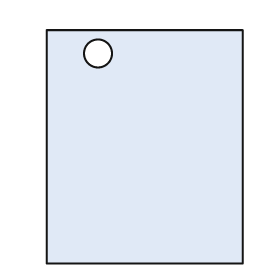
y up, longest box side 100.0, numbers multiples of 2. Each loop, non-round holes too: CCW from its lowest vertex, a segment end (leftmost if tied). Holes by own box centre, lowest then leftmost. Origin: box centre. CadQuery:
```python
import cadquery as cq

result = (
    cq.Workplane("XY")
    .moveTo(-42.0, -50.0)
    .lineTo(42.0, -50.0)
    .lineTo(42.0, 50.0)
    .lineTo(-42.0, 50.0)
    .close()
    .moveTo(-20.0, 40.0)
    .circle(6.0)
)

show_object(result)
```